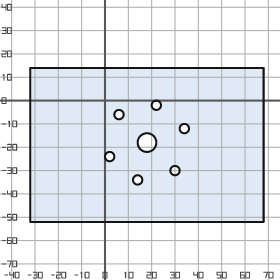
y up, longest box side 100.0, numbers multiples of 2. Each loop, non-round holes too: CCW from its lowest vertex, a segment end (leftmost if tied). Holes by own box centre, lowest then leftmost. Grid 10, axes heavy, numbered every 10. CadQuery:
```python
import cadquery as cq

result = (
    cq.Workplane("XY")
    .moveTo(-32.0, -52.0)
    .lineTo(68.0, -52.0)
    .lineTo(68.0, 14.0)
    .lineTo(-32.0, 14.0)
    .close()
    .moveTo(14.0, -34.0)
    .circle(2.0)
    .moveTo(30.0, -30.0)
    .circle(2.0)
    .moveTo(2.0, -24.0)
    .circle(2.0)
    .moveTo(18.0, -18.0)
    .circle(4.0)
    .moveTo(34.0, -12.0)
    .circle(2.0)
    .moveTo(6.0, -6.0)
    .circle(2.0)
    .moveTo(22.0, -2.0)
    .circle(2.0)
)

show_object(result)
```